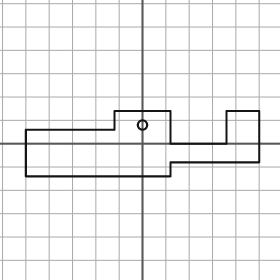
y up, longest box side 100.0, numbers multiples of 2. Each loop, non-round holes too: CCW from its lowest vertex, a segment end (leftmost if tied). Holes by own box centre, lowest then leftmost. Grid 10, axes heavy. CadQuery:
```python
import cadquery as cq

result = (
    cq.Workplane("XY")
    .moveTo(-50.0, -14.0)
    .lineTo(12.0, -14.0)
    .lineTo(12.0, -8.0)
    .lineTo(50.0, -8.0)
    .lineTo(50.0, 14.0)
    .lineTo(36.0, 14.0)
    .lineTo(36.0, 0.0)
    .lineTo(12.0, 0.0)
    .lineTo(12.0, 14.0)
    .lineTo(-12.0, 14.0)
    .lineTo(-12.0, 6.0)
    .lineTo(-50.0, 6.0)
    .close()
    .moveTo(0.0, 8.0)
    .circle(2.0)
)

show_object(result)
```